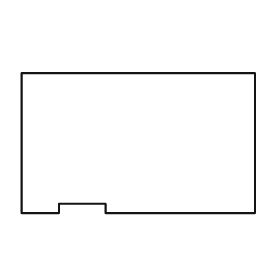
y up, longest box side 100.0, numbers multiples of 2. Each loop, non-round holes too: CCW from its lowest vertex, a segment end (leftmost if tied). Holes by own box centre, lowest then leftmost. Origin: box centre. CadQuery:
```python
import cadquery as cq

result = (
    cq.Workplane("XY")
    .moveTo(-50.0, -30.0)
    .lineTo(-34.0, -30.0)
    .lineTo(-34.0, -26.0)
    .lineTo(-14.0, -26.0)
    .lineTo(-14.0, -30.0)
    .lineTo(50.0, -30.0)
    .lineTo(50.0, 30.0)
    .lineTo(-50.0, 30.0)
    .close()
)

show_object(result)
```